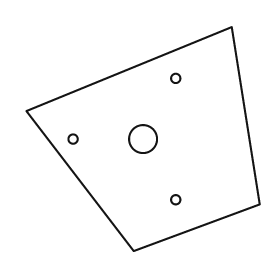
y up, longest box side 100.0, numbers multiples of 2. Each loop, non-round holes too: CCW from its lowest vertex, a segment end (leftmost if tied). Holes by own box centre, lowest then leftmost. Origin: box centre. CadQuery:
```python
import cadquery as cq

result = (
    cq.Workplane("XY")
    .moveTo(-4.0, -48.0)
    .lineTo(50.0, -28.0)
    .lineTo(38.0, 48.0)
    .lineTo(-50.0, 12.0)
    .close()
    .moveTo(14.0, -26.0)
    .circle(2.0)
    .moveTo(-30.0, 0.0)
    .circle(2.0)
    .moveTo(0.0, 0.0)
    .circle(6.0)
    .moveTo(14.0, 26.0)
    .circle(2.0)
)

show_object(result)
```